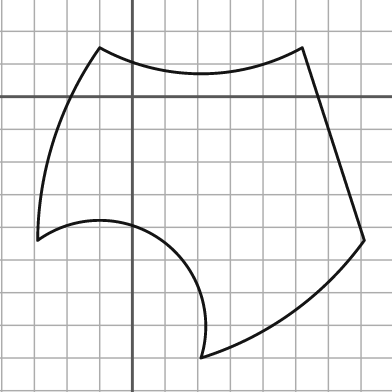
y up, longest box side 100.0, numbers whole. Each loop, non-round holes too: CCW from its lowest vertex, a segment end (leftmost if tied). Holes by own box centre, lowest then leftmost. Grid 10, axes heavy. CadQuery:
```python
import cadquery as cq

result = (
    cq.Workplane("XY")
    .moveTo(21.0, -80.0)
    .threePointArc((49.0, -66.0), (71.0, -44.0))
    .lineTo(52.0, 15.0)
    .threePointArc((21.0, 7.0), (-10.0, 15.0))
    .threePointArc((-24.0, -13.0), (-29.0, -44.0))
    .threePointArc((9.0, -44.0), (21.0, -80.0))
    .close()
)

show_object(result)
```